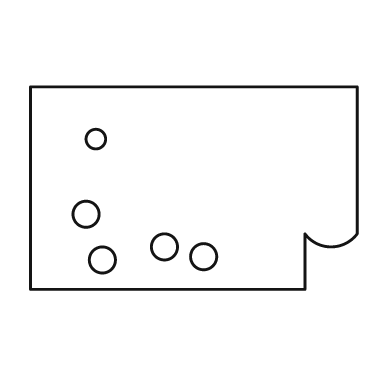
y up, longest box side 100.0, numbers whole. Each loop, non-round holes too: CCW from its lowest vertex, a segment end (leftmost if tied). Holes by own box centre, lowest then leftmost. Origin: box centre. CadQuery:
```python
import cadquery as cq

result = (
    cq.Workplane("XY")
    .moveTo(-50.0, -31.0)
    .lineTo(34.0, -31.0)
    .lineTo(34.0, -14.0)
    .threePointArc((42.0, -18.0), (50.0, -14.0))
    .lineTo(50.0, 31.0)
    .lineTo(-50.0, 31.0)
    .close()
    .moveTo(-28.0, -22.0)
    .circle(4.0)
    .moveTo(3.0, -21.0)
    .circle(4.0)
    .moveTo(-9.0, -18.0)
    .circle(4.0)
    .moveTo(-33.0, -8.0)
    .circle(4.0)
    .moveTo(-30.0, 15.0)
    .circle(3.0)
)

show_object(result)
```